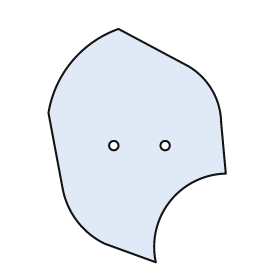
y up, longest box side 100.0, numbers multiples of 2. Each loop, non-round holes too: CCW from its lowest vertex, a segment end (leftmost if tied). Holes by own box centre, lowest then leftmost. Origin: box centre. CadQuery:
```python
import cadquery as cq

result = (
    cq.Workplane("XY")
    .moveTo(8.0, -50.0)
    .threePointArc((14.0, -24.0), (38.0, -12.0))
    .lineTo(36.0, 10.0)
    .threePointArc((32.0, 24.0), (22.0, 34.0))
    .lineTo(-8.0, 50.0)
    .threePointArc((-28.0, 36.0), (-38.0, 14.0))
    .lineTo(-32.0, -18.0)
    .threePointArc((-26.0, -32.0), (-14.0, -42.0))
    .close()
    .moveTo(-10.0, 0.0)
    .circle(2.0)
    .moveTo(12.0, 0.0)
    .circle(2.0)
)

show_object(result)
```